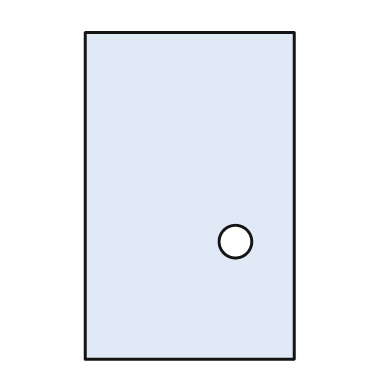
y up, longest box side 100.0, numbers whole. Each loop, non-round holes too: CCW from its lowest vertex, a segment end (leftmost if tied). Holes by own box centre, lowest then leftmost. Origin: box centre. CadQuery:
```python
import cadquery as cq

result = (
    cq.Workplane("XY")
    .moveTo(-32.0, -50.0)
    .lineTo(32.0, -50.0)
    .lineTo(32.0, 50.0)
    .lineTo(-32.0, 50.0)
    .close()
    .moveTo(14.0, -14.0)
    .circle(5.0)
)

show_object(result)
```